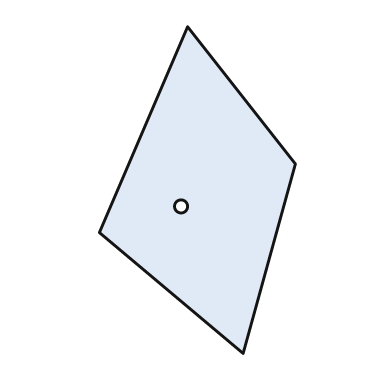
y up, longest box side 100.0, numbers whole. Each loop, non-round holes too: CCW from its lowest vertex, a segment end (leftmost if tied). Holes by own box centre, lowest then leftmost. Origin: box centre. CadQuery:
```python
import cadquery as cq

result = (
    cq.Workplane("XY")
    .moveTo(14.0, -50.0)
    .lineTo(30.0, 8.0)
    .lineTo(-3.0, 50.0)
    .lineTo(-30.0, -13.0)
    .close()
    .moveTo(-5.0, -5.0)
    .circle(2.0)
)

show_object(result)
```